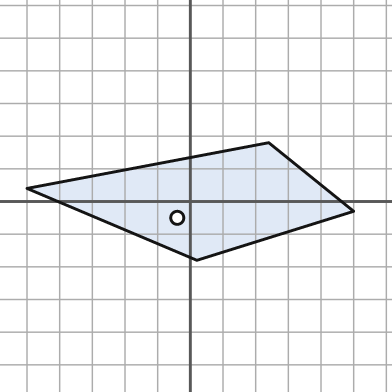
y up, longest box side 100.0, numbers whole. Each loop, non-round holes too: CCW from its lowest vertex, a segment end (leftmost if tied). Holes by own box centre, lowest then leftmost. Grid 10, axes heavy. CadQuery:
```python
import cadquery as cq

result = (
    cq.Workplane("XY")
    .moveTo(2.0, -18.0)
    .lineTo(50.0, -3.0)
    .lineTo(24.0, 18.0)
    .lineTo(-50.0, 4.0)
    .close()
    .moveTo(-4.0, -5.0)
    .circle(2.0)
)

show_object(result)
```